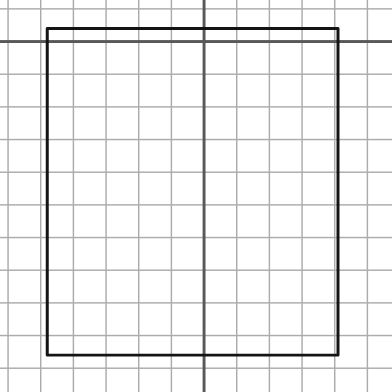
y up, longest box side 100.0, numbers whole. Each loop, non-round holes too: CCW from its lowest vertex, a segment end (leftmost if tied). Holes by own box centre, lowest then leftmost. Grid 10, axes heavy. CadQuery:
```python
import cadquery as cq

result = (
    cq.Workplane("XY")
    .moveTo(-48.0, -96.0)
    .lineTo(41.0, -96.0)
    .lineTo(41.0, 4.0)
    .lineTo(-48.0, 4.0)
    .close()
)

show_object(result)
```